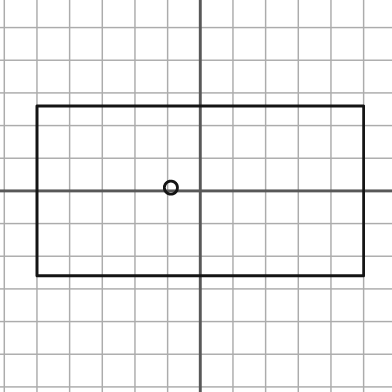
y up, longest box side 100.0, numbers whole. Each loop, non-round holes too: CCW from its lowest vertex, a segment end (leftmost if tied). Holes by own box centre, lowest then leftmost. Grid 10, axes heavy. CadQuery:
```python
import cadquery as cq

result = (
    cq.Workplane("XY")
    .moveTo(-50.0, -26.0)
    .lineTo(50.0, -26.0)
    .lineTo(50.0, 26.0)
    .lineTo(-50.0, 26.0)
    .close()
    .moveTo(-9.0, 1.0)
    .circle(2.0)
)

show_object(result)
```